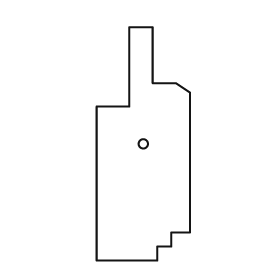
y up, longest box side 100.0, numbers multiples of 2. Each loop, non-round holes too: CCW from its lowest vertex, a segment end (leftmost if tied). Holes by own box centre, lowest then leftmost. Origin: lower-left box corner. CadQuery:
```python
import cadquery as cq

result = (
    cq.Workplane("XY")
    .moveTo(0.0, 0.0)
    .lineTo(26.0, 0.0)
    .lineTo(26.0, 6.0)
    .lineTo(32.0, 6.0)
    .lineTo(32.0, 12.0)
    .lineTo(40.0, 12.0)
    .lineTo(40.0, 72.0)
    .lineTo(34.0, 76.0)
    .lineTo(24.0, 76.0)
    .lineTo(24.0, 100.0)
    .lineTo(14.0, 100.0)
    .lineTo(14.0, 66.0)
    .lineTo(0.0, 66.0)
    .close()
    .moveTo(20.0, 50.0)
    .circle(2.0)
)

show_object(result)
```